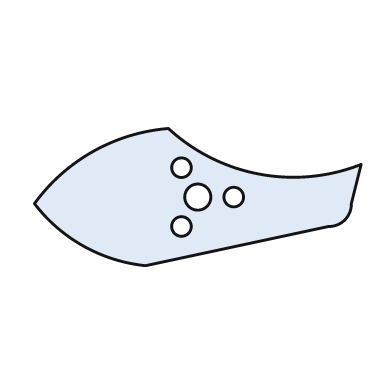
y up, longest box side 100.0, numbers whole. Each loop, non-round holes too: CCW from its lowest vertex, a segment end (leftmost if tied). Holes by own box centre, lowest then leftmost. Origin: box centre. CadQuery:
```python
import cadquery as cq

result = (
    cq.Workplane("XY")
    .moveTo(-16.0, -21.0)
    .lineTo(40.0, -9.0)
    .threePointArc((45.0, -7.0), (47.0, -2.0))
    .lineTo(50.0, 10.0)
    .threePointArc((19.0, 7.0), (-9.0, 21.0))
    .threePointArc((-32.0, 14.0), (-50.0, -2.0))
    .threePointArc((-35.0, -15.0), (-16.0, -21.0))
    .close()
    .moveTo(-5.0, -9.0)
    .circle(3.0)
    .moveTo(0.0, 0.0)
    .circle(4.0)
    .moveTo(11.0, 0.0)
    .circle(3.0)
    .moveTo(-5.0, 9.0)
    .circle(3.0)
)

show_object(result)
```